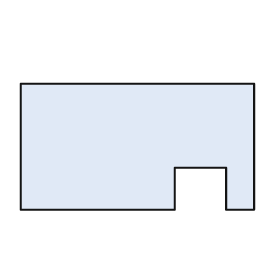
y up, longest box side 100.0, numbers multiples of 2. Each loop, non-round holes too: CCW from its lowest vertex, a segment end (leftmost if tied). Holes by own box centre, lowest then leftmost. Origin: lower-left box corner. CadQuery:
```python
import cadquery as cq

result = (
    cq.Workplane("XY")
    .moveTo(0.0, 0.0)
    .lineTo(66.0, 0.0)
    .lineTo(66.0, 18.0)
    .lineTo(88.0, 18.0)
    .lineTo(88.0, 0.0)
    .lineTo(100.0, 0.0)
    .lineTo(100.0, 54.0)
    .lineTo(0.0, 54.0)
    .close()
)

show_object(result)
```